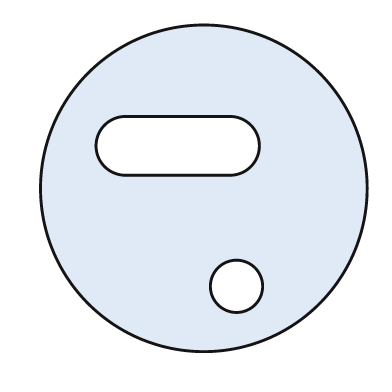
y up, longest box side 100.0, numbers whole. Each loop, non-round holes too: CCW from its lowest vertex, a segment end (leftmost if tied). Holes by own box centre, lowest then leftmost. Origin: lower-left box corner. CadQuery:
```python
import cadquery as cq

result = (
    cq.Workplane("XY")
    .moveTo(50.0, 50.0)
    .circle(50.0)
    .moveTo(60.0, 20.0)
    .circle(8.0)
    .moveTo(26.0, 54.0)
    .lineTo(58.0, 54.0)
    .threePointArc((67.0, 63.0), (58.0, 72.0))
    .lineTo(26.0, 72.0)
    .threePointArc((17.0, 63.0), (26.0, 54.0))
    .close()
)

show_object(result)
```